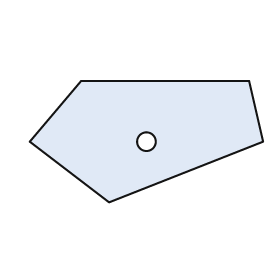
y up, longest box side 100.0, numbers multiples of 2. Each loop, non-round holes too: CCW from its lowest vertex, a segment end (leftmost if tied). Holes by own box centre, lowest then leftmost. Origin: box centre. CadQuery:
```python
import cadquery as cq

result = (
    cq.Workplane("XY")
    .moveTo(-16.0, -26.0)
    .lineTo(50.0, 0.0)
    .lineTo(44.0, 26.0)
    .lineTo(-28.0, 26.0)
    .lineTo(-50.0, 0.0)
    .close()
    .moveTo(0.0, 0.0)
    .circle(4.0)
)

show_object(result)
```